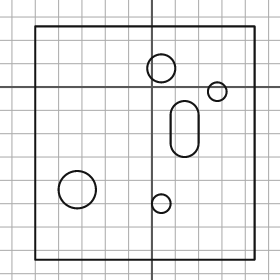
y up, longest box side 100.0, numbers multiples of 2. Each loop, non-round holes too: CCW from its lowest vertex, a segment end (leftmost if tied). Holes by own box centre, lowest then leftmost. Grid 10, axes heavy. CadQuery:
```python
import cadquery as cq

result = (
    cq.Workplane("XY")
    .moveTo(-50.0, -74.0)
    .lineTo(44.0, -74.0)
    .lineTo(44.0, 26.0)
    .lineTo(-50.0, 26.0)
    .close()
    .moveTo(4.0, -50.0)
    .circle(4.0)
    .moveTo(-32.0, -44.0)
    .circle(8.0)
    .moveTo(8.0, -24.0)
    .threePointArc((14.0, -30.0), (20.0, -24.0))
    .lineTo(20.0, -12.0)
    .threePointArc((14.0, -6.0), (8.0, -12.0))
    .close()
    .moveTo(28.0, -2.0)
    .circle(4.0)
    .moveTo(4.0, 8.0)
    .circle(6.0)
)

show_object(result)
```